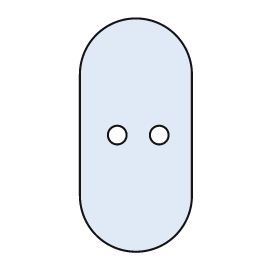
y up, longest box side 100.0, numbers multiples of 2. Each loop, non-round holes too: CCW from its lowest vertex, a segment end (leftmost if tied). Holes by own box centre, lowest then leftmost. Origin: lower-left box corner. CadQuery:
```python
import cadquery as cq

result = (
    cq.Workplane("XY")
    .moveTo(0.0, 24.0)
    .threePointArc((24.0, 0.0), (48.0, 24.0))
    .lineTo(48.0, 76.0)
    .threePointArc((24.0, 100.0), (0.0, 76.0))
    .close()
    .moveTo(16.0, 50.0)
    .circle(4.0)
    .moveTo(34.0, 50.0)
    .circle(4.0)
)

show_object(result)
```